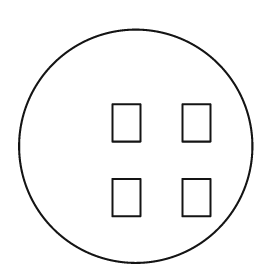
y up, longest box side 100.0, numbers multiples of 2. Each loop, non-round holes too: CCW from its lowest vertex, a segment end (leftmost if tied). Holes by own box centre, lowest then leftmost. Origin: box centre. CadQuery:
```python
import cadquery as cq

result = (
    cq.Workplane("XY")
    .moveTo(0.0, 0.0)
    .circle(50.0)
    .moveTo(-10.0, -30.0)
    .lineTo(2.0, -30.0)
    .lineTo(2.0, -14.0)
    .lineTo(-10.0, -14.0)
    .close()
    .moveTo(20.0, -30.0)
    .lineTo(32.0, -30.0)
    .lineTo(32.0, -14.0)
    .lineTo(20.0, -14.0)
    .close()
    .moveTo(-10.0, 2.0)
    .lineTo(2.0, 2.0)
    .lineTo(2.0, 18.0)
    .lineTo(-10.0, 18.0)
    .close()
    .moveTo(20.0, 2.0)
    .lineTo(32.0, 2.0)
    .lineTo(32.0, 18.0)
    .lineTo(20.0, 18.0)
    .close()
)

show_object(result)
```